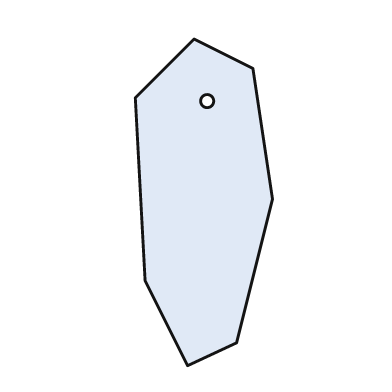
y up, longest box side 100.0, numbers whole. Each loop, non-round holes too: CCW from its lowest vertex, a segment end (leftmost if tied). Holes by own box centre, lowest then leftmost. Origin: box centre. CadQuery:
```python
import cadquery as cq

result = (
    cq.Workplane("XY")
    .moveTo(-5.0, -50.0)
    .lineTo(10.0, -43.0)
    .lineTo(21.0, 1.0)
    .lineTo(15.0, 41.0)
    .lineTo(-3.0, 50.0)
    .lineTo(-21.0, 32.0)
    .lineTo(-18.0, -24.0)
    .close()
    .moveTo(1.0, 31.0)
    .circle(2.0)
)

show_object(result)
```